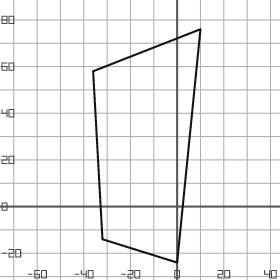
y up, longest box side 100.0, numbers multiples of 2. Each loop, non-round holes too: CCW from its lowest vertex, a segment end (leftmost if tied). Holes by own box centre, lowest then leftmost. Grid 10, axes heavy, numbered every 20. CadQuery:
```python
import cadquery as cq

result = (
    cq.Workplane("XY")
    .moveTo(0.0, -24.0)
    .lineTo(10.0, 76.0)
    .lineTo(-36.0, 58.0)
    .lineTo(-32.0, -14.0)
    .close()
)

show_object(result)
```